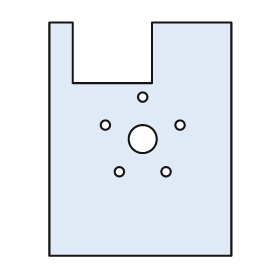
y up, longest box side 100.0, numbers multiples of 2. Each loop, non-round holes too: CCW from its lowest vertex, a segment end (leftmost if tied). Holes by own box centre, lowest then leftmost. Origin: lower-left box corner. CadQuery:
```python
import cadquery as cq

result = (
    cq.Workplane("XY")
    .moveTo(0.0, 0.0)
    .lineTo(78.0, 0.0)
    .lineTo(78.0, 100.0)
    .lineTo(44.0, 100.0)
    .lineTo(44.0, 74.0)
    .lineTo(10.0, 74.0)
    .lineTo(10.0, 100.0)
    .lineTo(0.0, 100.0)
    .close()
    .moveTo(30.0, 36.0)
    .circle(2.0)
    .moveTo(50.0, 36.0)
    .circle(2.0)
    .moveTo(40.0, 50.0)
    .circle(6.0)
    .moveTo(24.0, 56.0)
    .circle(2.0)
    .moveTo(56.0, 56.0)
    .circle(2.0)
    .moveTo(40.0, 68.0)
    .circle(2.0)
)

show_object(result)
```